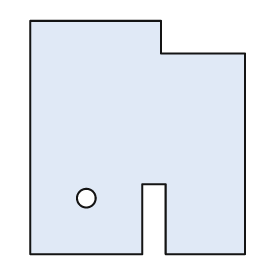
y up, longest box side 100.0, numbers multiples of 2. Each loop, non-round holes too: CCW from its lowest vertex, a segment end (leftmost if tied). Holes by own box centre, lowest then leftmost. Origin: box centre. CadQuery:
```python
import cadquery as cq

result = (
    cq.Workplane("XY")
    .moveTo(-46.0, -50.0)
    .lineTo(2.0, -50.0)
    .lineTo(2.0, -20.0)
    .lineTo(12.0, -20.0)
    .lineTo(12.0, -50.0)
    .lineTo(46.0, -50.0)
    .lineTo(46.0, 36.0)
    .lineTo(10.0, 36.0)
    .lineTo(10.0, 50.0)
    .lineTo(-46.0, 50.0)
    .close()
    .moveTo(-22.0, -26.0)
    .circle(4.0)
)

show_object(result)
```